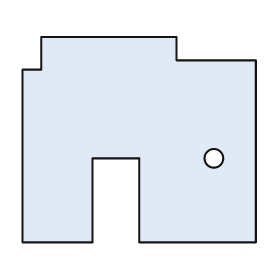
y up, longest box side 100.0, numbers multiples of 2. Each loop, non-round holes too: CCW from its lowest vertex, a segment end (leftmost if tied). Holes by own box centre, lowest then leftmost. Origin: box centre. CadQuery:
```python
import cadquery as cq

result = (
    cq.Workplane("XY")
    .moveTo(-50.0, -44.0)
    .lineTo(-20.0, -44.0)
    .lineTo(-20.0, -8.0)
    .lineTo(0.0, -8.0)
    .lineTo(0.0, -44.0)
    .lineTo(50.0, -44.0)
    .lineTo(50.0, 34.0)
    .lineTo(16.0, 34.0)
    .lineTo(16.0, 44.0)
    .lineTo(-42.0, 44.0)
    .lineTo(-42.0, 30.0)
    .lineTo(-50.0, 30.0)
    .close()
    .moveTo(32.0, -8.0)
    .circle(4.0)
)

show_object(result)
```